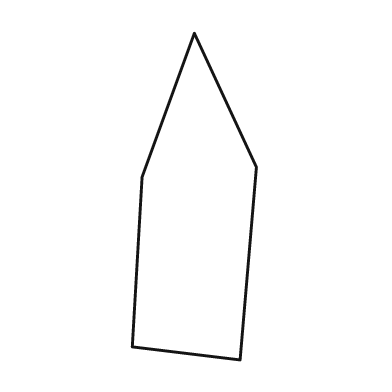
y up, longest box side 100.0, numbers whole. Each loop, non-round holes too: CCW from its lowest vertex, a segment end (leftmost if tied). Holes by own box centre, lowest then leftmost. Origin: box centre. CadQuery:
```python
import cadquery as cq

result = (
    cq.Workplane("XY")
    .moveTo(14.0, -50.0)
    .lineTo(19.0, 9.0)
    .lineTo(0.0, 50.0)
    .lineTo(-16.0, 6.0)
    .lineTo(-19.0, -46.0)
    .close()
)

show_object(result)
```